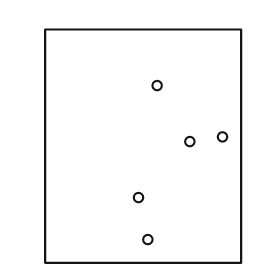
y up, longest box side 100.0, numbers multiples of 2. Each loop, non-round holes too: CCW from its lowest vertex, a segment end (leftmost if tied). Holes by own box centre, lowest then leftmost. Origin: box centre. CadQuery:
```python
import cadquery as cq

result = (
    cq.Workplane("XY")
    .moveTo(-42.0, -50.0)
    .lineTo(42.0, -50.0)
    .lineTo(42.0, 50.0)
    .lineTo(-42.0, 50.0)
    .close()
    .moveTo(2.0, -40.0)
    .circle(2.0)
    .moveTo(-2.0, -22.0)
    .circle(2.0)
    .moveTo(20.0, 2.0)
    .circle(2.0)
    .moveTo(34.0, 4.0)
    .circle(2.0)
    .moveTo(6.0, 26.0)
    .circle(2.0)
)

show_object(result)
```